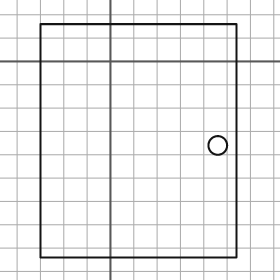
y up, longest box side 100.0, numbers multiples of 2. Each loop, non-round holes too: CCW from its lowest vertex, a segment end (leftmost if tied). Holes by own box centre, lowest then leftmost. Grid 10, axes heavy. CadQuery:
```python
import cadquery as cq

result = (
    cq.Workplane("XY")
    .moveTo(-30.0, -84.0)
    .lineTo(54.0, -84.0)
    .lineTo(54.0, 16.0)
    .lineTo(-30.0, 16.0)
    .close()
    .moveTo(46.0, -36.0)
    .circle(4.0)
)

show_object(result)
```